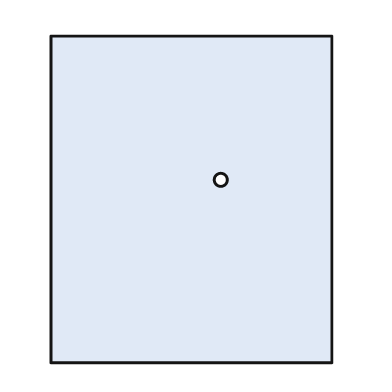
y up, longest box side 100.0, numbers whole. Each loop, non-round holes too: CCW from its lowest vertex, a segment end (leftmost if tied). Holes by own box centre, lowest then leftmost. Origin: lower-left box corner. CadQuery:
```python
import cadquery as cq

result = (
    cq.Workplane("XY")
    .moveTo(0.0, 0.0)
    .lineTo(86.0, 0.0)
    .lineTo(86.0, 100.0)
    .lineTo(0.0, 100.0)
    .close()
    .moveTo(52.0, 56.0)
    .circle(2.0)
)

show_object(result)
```